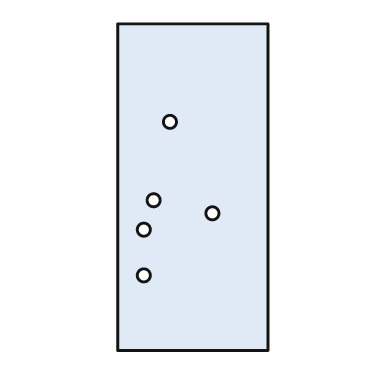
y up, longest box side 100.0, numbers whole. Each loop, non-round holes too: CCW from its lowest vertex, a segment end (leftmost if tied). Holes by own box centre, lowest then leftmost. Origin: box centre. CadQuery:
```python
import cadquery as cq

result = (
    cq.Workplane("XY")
    .moveTo(-23.0, -50.0)
    .lineTo(23.0, -50.0)
    .lineTo(23.0, 50.0)
    .lineTo(-23.0, 50.0)
    .close()
    .moveTo(-15.0, -27.0)
    .circle(2.0)
    .moveTo(-15.0, -13.0)
    .circle(2.0)
    .moveTo(6.0, -8.0)
    .circle(2.0)
    .moveTo(-12.0, -4.0)
    .circle(2.0)
    .moveTo(-7.0, 20.0)
    .circle(2.0)
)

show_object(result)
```